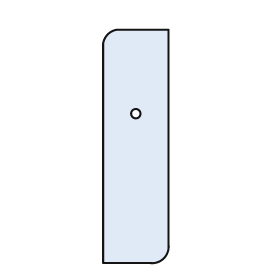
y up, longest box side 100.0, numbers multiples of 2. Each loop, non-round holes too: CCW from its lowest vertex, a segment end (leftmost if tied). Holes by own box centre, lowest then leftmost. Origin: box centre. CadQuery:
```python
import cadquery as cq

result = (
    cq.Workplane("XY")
    .moveTo(-14.0, -50.0)
    .lineTo(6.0, -50.0)
    .threePointArc((12.0, -48.0), (14.0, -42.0))
    .lineTo(14.0, 50.0)
    .lineTo(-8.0, 50.0)
    .threePointArc((-12.0, 48.0), (-14.0, 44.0))
    .close()
    .moveTo(0.0, 14.0)
    .circle(2.0)
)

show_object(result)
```